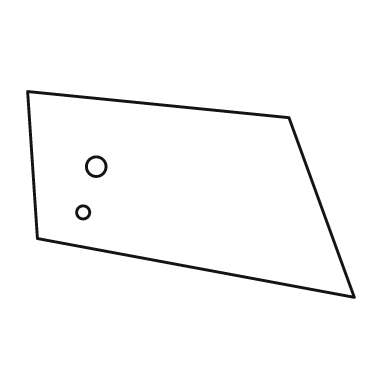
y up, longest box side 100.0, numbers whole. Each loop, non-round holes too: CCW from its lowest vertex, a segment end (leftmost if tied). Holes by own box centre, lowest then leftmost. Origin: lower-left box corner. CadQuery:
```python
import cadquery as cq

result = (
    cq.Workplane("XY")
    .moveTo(100.0, 0.0)
    .lineTo(80.0, 55.0)
    .lineTo(0.0, 63.0)
    .lineTo(3.0, 18.0)
    .close()
    .moveTo(17.0, 26.0)
    .circle(2.0)
    .moveTo(21.0, 40.0)
    .circle(3.0)
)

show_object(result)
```